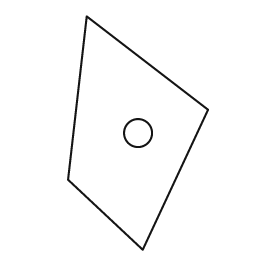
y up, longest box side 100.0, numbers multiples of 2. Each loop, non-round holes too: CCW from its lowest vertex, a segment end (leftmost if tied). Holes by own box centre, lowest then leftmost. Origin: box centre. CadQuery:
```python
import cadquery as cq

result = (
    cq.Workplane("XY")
    .moveTo(2.0, -50.0)
    .lineTo(30.0, 10.0)
    .lineTo(-22.0, 50.0)
    .lineTo(-30.0, -20.0)
    .close()
    .moveTo(0.0, 0.0)
    .circle(6.0)
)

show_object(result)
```